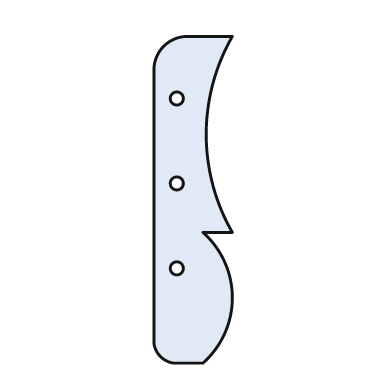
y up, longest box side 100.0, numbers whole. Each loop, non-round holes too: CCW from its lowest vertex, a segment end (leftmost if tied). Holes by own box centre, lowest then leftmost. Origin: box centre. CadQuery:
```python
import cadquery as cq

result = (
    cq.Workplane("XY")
    .moveTo(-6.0, -50.0)
    .lineTo(3.0, -50.0)
    .threePointArc((12.0, -30.0), (3.0, -10.0))
    .lineTo(12.0, -10.0)
    .threePointArc((4.0, 20.0), (12.0, 50.0))
    .lineTo(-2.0, 50.0)
    .threePointArc((-9.0, 47.0), (-12.0, 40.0))
    .lineTo(-12.0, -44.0)
    .threePointArc((-10.0, -48.0), (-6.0, -50.0))
    .close()
    .moveTo(-5.0, -21.0)
    .circle(2.0)
    .moveTo(-5.0, 5.0)
    .circle(2.0)
    .moveTo(-5.0, 31.0)
    .circle(2.0)
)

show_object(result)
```